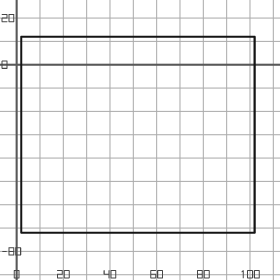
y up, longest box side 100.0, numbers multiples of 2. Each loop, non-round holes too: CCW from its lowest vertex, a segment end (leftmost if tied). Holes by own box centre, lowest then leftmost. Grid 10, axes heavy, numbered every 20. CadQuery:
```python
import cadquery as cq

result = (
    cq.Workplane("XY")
    .moveTo(2.0, -72.0)
    .lineTo(102.0, -72.0)
    .lineTo(102.0, 12.0)
    .lineTo(2.0, 12.0)
    .close()
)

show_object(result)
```